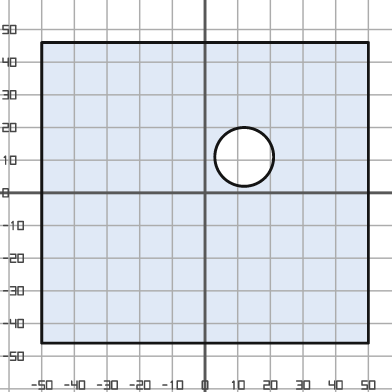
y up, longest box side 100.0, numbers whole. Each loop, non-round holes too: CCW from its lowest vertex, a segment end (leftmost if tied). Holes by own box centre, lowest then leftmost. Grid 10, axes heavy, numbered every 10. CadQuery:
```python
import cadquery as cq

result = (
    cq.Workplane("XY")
    .moveTo(-50.0, -46.0)
    .lineTo(50.0, -46.0)
    .lineTo(50.0, 46.0)
    .lineTo(-50.0, 46.0)
    .close()
    .moveTo(12.0, 11.0)
    .circle(9.0)
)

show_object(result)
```